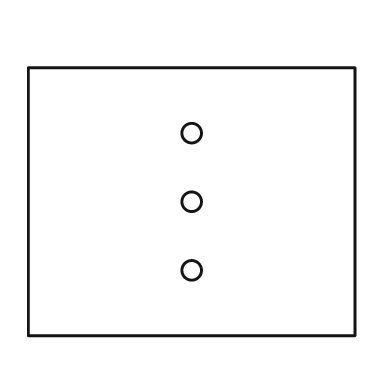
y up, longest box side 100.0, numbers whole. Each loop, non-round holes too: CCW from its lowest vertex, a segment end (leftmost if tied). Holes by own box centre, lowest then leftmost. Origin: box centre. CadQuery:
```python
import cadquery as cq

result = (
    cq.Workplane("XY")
    .moveTo(-50.0, -41.0)
    .lineTo(50.0, -41.0)
    .lineTo(50.0, 41.0)
    .lineTo(-50.0, 41.0)
    .close()
    .moveTo(0.0, -21.0)
    .circle(3.0)
    .moveTo(0.0, 0.0)
    .circle(3.0)
    .moveTo(0.0, 21.0)
    .circle(3.0)
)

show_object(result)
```